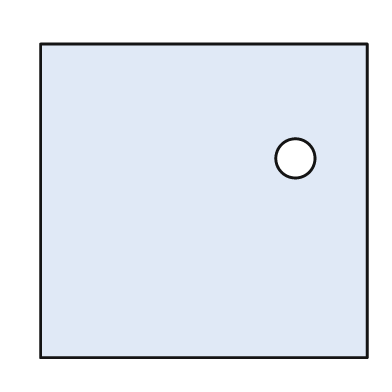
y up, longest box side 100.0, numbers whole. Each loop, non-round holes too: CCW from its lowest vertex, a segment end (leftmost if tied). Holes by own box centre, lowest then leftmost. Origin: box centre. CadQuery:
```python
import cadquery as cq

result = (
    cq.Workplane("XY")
    .moveTo(-50.0, -48.0)
    .lineTo(50.0, -48.0)
    .lineTo(50.0, 48.0)
    .lineTo(-50.0, 48.0)
    .close()
    .moveTo(28.0, 13.0)
    .circle(6.0)
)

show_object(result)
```